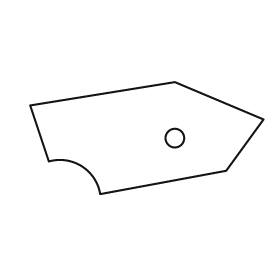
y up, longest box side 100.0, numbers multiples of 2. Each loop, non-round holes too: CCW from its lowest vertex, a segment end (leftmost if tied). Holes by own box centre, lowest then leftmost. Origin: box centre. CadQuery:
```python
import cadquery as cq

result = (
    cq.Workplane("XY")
    .moveTo(-20.0, -24.0)
    .lineTo(34.0, -14.0)
    .lineTo(50.0, 8.0)
    .lineTo(12.0, 24.0)
    .lineTo(-50.0, 14.0)
    .lineTo(-42.0, -10.0)
    .threePointArc((-28.0, -12.0), (-20.0, -24.0))
    .close()
    .moveTo(12.0, 0.0)
    .circle(4.0)
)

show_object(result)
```